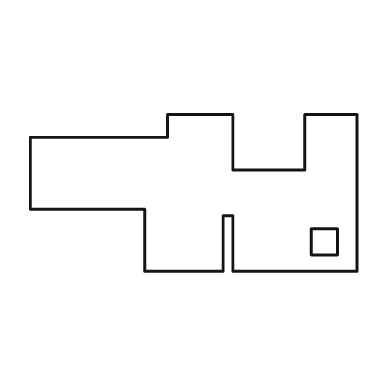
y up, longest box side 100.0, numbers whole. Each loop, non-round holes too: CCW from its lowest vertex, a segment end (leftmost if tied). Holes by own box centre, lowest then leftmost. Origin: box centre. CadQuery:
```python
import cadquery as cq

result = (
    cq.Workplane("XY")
    .moveTo(-15.0, -24.0)
    .lineTo(9.0, -24.0)
    .lineTo(9.0, -7.0)
    .lineTo(12.0, -7.0)
    .lineTo(12.0, -24.0)
    .lineTo(50.0, -24.0)
    .lineTo(50.0, 24.0)
    .lineTo(34.0, 24.0)
    .lineTo(34.0, 7.0)
    .lineTo(12.0, 7.0)
    .lineTo(12.0, 24.0)
    .lineTo(-8.0, 24.0)
    .lineTo(-8.0, 17.0)
    .lineTo(-50.0, 17.0)
    .lineTo(-50.0, -5.0)
    .lineTo(-15.0, -5.0)
    .close()
    .moveTo(36.0, -19.0)
    .lineTo(44.0, -19.0)
    .lineTo(44.0, -11.0)
    .lineTo(36.0, -11.0)
    .close()
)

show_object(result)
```